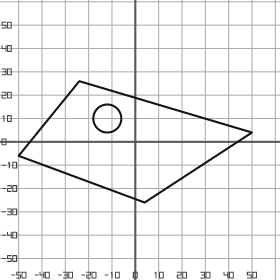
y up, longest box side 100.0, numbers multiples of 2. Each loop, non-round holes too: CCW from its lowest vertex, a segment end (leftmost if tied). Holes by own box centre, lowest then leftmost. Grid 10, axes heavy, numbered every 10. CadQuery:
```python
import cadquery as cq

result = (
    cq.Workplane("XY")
    .moveTo(4.0, -26.0)
    .lineTo(50.0, 4.0)
    .lineTo(-24.0, 26.0)
    .lineTo(-50.0, -6.0)
    .close()
    .moveTo(-12.0, 10.0)
    .circle(6.0)
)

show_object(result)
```